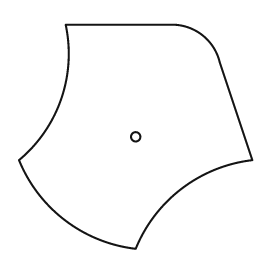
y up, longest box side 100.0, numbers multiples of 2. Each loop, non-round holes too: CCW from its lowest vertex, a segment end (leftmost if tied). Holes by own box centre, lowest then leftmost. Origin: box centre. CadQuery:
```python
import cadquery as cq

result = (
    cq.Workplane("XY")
    .moveTo(0.0, -48.0)
    .threePointArc((20.0, -22.0), (50.0, -10.0))
    .lineTo(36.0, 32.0)
    .threePointArc((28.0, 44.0), (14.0, 48.0))
    .lineTo(-30.0, 48.0)
    .threePointArc((-32.0, 16.0), (-50.0, -10.0))
    .threePointArc((-30.0, -36.0), (0.0, -48.0))
    .close()
    .moveTo(0.0, 0.0)
    .circle(2.0)
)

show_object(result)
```